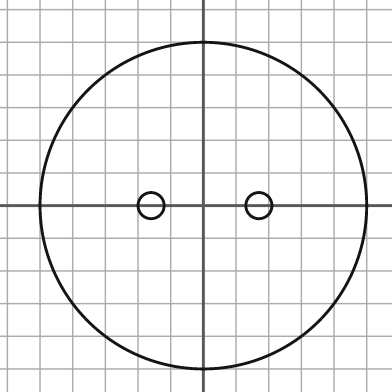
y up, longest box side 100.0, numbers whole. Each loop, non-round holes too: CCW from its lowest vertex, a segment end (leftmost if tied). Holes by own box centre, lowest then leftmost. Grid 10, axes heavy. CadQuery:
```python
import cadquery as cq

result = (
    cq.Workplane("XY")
    .moveTo(0.0, 0.0)
    .circle(50.0)
    .moveTo(-16.0, 0.0)
    .circle(4.0)
    .moveTo(17.0, 0.0)
    .circle(4.0)
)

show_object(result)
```